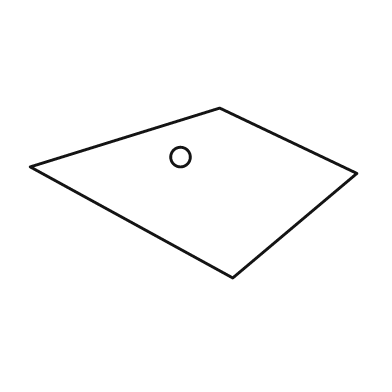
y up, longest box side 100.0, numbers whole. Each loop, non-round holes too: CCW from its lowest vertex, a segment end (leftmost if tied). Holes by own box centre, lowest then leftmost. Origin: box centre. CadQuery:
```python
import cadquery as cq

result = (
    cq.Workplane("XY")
    .moveTo(12.0, -26.0)
    .lineTo(50.0, 6.0)
    .lineTo(8.0, 26.0)
    .lineTo(-50.0, 8.0)
    .close()
    .moveTo(-4.0, 11.0)
    .circle(3.0)
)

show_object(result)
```